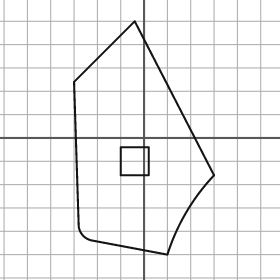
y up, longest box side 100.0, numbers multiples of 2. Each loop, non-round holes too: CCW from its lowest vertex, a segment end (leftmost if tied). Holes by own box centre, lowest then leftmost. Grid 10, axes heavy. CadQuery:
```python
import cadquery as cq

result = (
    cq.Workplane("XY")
    .moveTo(10.0, -50.0)
    .threePointArc((18.0, -32.0), (30.0, -16.0))
    .lineTo(-4.0, 50.0)
    .lineTo(-30.0, 24.0)
    .lineTo(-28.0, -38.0)
    .threePointArc((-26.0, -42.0), (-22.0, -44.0))
    .close()
    .moveTo(-10.0, -16.0)
    .lineTo(2.0, -16.0)
    .lineTo(2.0, -4.0)
    .lineTo(-10.0, -4.0)
    .close()
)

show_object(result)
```